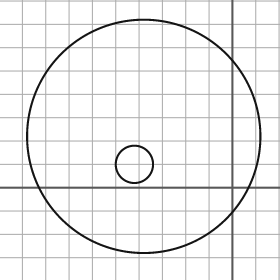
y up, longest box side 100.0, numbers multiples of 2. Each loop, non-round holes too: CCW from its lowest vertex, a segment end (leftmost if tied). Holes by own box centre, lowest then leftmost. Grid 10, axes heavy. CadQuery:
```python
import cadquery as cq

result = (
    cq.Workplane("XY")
    .moveTo(-38.0, 22.0)
    .circle(50.0)
    .moveTo(-42.0, 10.0)
    .circle(8.0)
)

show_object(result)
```